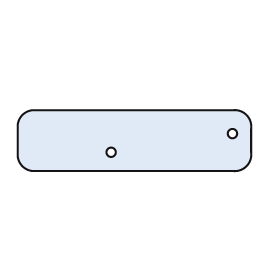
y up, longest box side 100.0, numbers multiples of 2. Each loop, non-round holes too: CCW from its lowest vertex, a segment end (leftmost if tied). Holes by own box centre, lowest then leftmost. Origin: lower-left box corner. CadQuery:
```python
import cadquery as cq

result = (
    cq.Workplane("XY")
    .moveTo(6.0, 0.0)
    .lineTo(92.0, 0.0)
    .threePointArc((98.0, 2.0), (100.0, 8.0))
    .lineTo(100.0, 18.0)
    .threePointArc((98.0, 24.0), (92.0, 26.0))
    .lineTo(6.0, 26.0)
    .threePointArc((2.0, 24.0), (0.0, 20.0))
    .lineTo(0.0, 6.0)
    .threePointArc((2.0, 2.0), (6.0, 0.0))
    .close()
    .moveTo(40.0, 8.0)
    .circle(2.0)
    .moveTo(92.0, 16.0)
    .circle(2.0)
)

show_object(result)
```